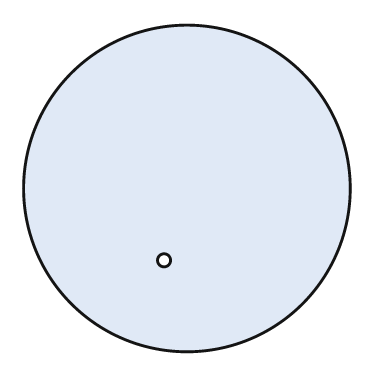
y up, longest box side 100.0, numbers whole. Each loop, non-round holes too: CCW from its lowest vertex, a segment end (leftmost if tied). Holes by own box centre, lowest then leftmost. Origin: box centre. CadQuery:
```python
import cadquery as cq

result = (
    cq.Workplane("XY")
    .moveTo(0.0, 0.0)
    .circle(50.0)
    .moveTo(-7.0, -22.0)
    .circle(2.0)
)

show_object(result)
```